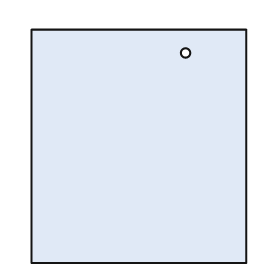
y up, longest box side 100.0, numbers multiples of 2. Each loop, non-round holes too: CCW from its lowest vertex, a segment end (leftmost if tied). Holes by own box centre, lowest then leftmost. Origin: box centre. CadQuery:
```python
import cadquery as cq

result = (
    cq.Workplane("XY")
    .moveTo(-46.0, -50.0)
    .lineTo(46.0, -50.0)
    .lineTo(46.0, 50.0)
    .lineTo(-46.0, 50.0)
    .close()
    .moveTo(20.0, 40.0)
    .circle(2.0)
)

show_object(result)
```